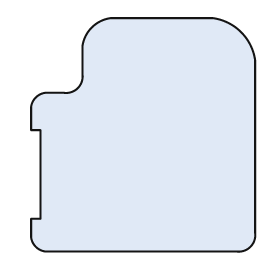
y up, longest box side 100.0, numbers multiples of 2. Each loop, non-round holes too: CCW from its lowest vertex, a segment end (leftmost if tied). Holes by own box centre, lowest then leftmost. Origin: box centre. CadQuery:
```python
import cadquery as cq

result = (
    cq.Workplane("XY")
    .moveTo(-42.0, -50.0)
    .lineTo(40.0, -50.0)
    .threePointArc((46.0, -48.0), (48.0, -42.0))
    .lineTo(48.0, 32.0)
    .threePointArc((42.0, 44.0), (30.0, 50.0))
    .lineTo(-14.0, 50.0)
    .threePointArc((-22.0, 46.0), (-26.0, 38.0))
    .lineTo(-26.0, 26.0)
    .threePointArc((-28.0, 20.0), (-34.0, 18.0))
    .lineTo(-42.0, 18.0)
    .threePointArc((-46.0, 16.0), (-48.0, 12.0))
    .lineTo(-48.0, 2.0)
    .lineTo(-44.0, 2.0)
    .lineTo(-44.0, -36.0)
    .lineTo(-48.0, -36.0)
    .lineTo(-48.0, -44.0)
    .threePointArc((-46.0, -48.0), (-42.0, -50.0))
    .close()
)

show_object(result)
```